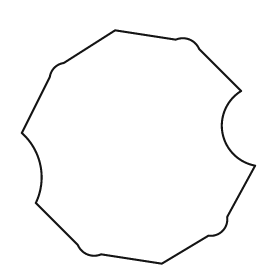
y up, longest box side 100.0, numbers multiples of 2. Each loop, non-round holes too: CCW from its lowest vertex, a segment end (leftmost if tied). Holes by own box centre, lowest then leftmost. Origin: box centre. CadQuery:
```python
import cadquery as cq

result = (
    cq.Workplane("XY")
    .moveTo(10.0, -50.0)
    .lineTo(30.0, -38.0)
    .threePointArc((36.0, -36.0), (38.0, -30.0))
    .lineTo(50.0, -8.0)
    .threePointArc((36.0, 6.0), (44.0, 24.0))
    .lineTo(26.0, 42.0)
    .threePointArc((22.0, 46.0), (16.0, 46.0))
    .lineTo(-10.0, 50.0)
    .lineTo(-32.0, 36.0)
    .threePointArc((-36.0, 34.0), (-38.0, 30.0))
    .lineTo(-50.0, 6.0)
    .threePointArc((-42.0, -8.0), (-44.0, -24.0))
    .lineTo(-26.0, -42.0)
    .threePointArc((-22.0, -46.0), (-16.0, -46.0))
    .close()
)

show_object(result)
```